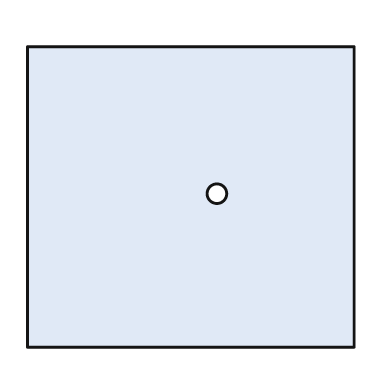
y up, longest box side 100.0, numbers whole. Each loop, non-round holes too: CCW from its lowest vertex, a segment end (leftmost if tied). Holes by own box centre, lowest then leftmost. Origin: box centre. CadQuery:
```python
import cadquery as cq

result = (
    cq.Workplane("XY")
    .moveTo(-50.0, -46.0)
    .lineTo(50.0, -46.0)
    .lineTo(50.0, 46.0)
    .lineTo(-50.0, 46.0)
    .close()
    .moveTo(8.0, 1.0)
    .circle(3.0)
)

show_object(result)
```